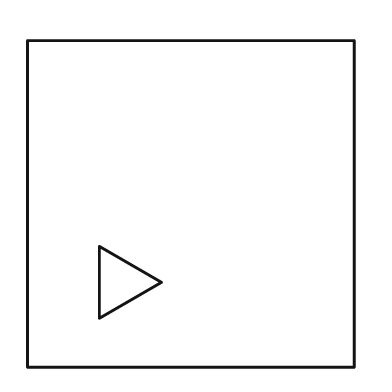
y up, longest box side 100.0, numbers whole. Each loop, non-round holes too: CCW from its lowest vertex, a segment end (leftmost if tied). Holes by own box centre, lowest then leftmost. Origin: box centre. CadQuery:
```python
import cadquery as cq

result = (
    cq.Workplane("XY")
    .moveTo(-50.0, -50.0)
    .lineTo(50.0, -50.0)
    .lineTo(50.0, 50.0)
    .lineTo(-50.0, 50.0)
    .close()
    .moveTo(-28.0, -35.0)
    .lineTo(-9.0, -24.0)
    .lineTo(-28.0, -13.0)
    .close()
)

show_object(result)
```